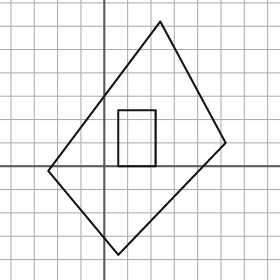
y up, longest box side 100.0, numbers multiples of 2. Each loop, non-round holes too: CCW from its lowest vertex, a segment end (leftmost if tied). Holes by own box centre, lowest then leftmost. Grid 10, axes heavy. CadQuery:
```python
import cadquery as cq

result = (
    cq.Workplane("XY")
    .moveTo(6.0, -38.0)
    .lineTo(52.0, 10.0)
    .lineTo(24.0, 62.0)
    .lineTo(-24.0, -2.0)
    .close()
    .moveTo(6.0, 0.0)
    .lineTo(22.0, 0.0)
    .lineTo(22.0, 24.0)
    .lineTo(6.0, 24.0)
    .close()
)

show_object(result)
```